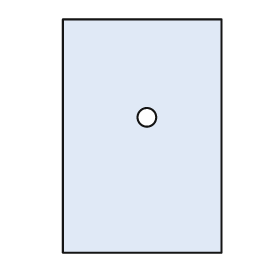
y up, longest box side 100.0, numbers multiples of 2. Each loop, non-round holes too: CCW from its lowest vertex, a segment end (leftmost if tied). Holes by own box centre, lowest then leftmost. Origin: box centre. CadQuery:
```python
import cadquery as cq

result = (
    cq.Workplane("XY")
    .moveTo(-34.0, -50.0)
    .lineTo(34.0, -50.0)
    .lineTo(34.0, 50.0)
    .lineTo(-34.0, 50.0)
    .close()
    .moveTo(2.0, 8.0)
    .circle(4.0)
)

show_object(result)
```